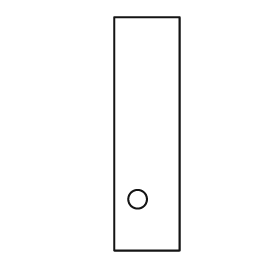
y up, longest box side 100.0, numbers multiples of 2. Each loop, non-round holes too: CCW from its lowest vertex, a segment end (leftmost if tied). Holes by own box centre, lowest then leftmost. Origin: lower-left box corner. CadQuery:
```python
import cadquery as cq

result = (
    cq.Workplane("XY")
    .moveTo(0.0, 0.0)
    .lineTo(28.0, 0.0)
    .lineTo(28.0, 100.0)
    .lineTo(0.0, 100.0)
    .close()
    .moveTo(10.0, 22.0)
    .circle(4.0)
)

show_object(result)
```